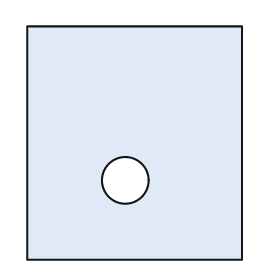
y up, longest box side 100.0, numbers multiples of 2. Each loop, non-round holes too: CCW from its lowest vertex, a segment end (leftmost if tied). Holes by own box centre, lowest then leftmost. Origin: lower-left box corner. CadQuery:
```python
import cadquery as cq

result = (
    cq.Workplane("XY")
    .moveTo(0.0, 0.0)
    .lineTo(92.0, 0.0)
    .lineTo(92.0, 100.0)
    .lineTo(0.0, 100.0)
    .close()
    .moveTo(42.0, 34.0)
    .circle(10.0)
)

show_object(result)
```